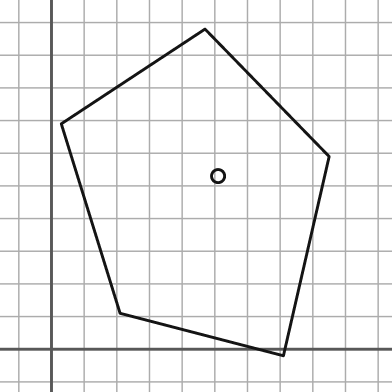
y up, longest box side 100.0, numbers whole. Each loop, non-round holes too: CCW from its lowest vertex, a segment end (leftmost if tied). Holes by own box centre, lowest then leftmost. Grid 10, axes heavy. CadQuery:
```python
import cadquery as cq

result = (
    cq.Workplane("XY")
    .moveTo(71.0, -2.0)
    .lineTo(85.0, 59.0)
    .lineTo(47.0, 98.0)
    .lineTo(3.0, 69.0)
    .lineTo(21.0, 11.0)
    .close()
    .moveTo(51.0, 53.0)
    .circle(2.0)
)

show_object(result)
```